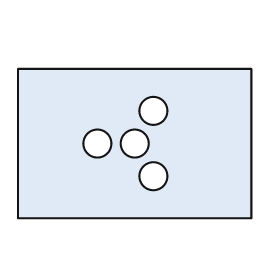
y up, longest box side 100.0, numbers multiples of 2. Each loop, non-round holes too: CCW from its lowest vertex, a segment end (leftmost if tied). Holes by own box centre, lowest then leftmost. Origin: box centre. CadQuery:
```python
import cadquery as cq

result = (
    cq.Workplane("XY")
    .moveTo(-50.0, -32.0)
    .lineTo(50.0, -32.0)
    .lineTo(50.0, 32.0)
    .lineTo(-50.0, 32.0)
    .close()
    .moveTo(8.0, -14.0)
    .circle(6.0)
    .moveTo(-16.0, 0.0)
    .circle(6.0)
    .moveTo(0.0, 0.0)
    .circle(6.0)
    .moveTo(8.0, 14.0)
    .circle(6.0)
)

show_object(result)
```